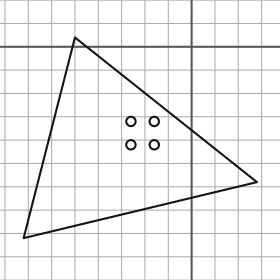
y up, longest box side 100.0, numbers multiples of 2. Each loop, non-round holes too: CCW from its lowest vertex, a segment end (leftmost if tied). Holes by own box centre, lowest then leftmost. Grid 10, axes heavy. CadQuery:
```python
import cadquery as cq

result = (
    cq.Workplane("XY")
    .moveTo(-72.0, -82.0)
    .lineTo(28.0, -58.0)
    .lineTo(-50.0, 4.0)
    .close()
    .moveTo(-26.0, -42.0)
    .circle(2.0)
    .moveTo(-16.0, -42.0)
    .circle(2.0)
    .moveTo(-26.0, -32.0)
    .circle(2.0)
    .moveTo(-16.0, -32.0)
    .circle(2.0)
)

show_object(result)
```